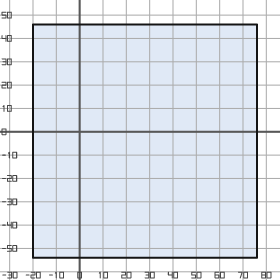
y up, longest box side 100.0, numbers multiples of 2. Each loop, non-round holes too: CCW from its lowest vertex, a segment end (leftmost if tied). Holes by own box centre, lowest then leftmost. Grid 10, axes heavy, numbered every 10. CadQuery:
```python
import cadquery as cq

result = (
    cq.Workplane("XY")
    .moveTo(-20.0, -54.0)
    .lineTo(76.0, -54.0)
    .lineTo(76.0, 46.0)
    .lineTo(-20.0, 46.0)
    .close()
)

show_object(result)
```